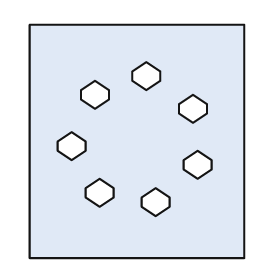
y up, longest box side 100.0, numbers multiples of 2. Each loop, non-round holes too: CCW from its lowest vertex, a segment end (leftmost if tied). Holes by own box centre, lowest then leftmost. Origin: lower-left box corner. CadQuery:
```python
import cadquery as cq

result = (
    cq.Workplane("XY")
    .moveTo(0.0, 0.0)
    .lineTo(92.0, 0.0)
    .lineTo(92.0, 100.0)
    .lineTo(0.0, 100.0)
    .close()
    .moveTo(54.0, 18.0)
    .lineTo(60.0, 22.0)
    .lineTo(60.0, 26.0)
    .lineTo(54.0, 30.0)
    .lineTo(48.0, 26.0)
    .lineTo(48.0, 22.0)
    .close()
    .moveTo(30.0, 22.0)
    .lineTo(36.0, 26.0)
    .lineTo(36.0, 30.0)
    .lineTo(30.0, 34.0)
    .lineTo(24.0, 30.0)
    .lineTo(24.0, 26.0)
    .close()
    .moveTo(72.0, 34.0)
    .lineTo(78.0, 38.0)
    .lineTo(78.0, 42.0)
    .lineTo(72.0, 46.0)
    .lineTo(66.0, 42.0)
    .lineTo(66.0, 38.0)
    .close()
    .moveTo(18.0, 42.0)
    .lineTo(24.0, 46.0)
    .lineTo(24.0, 50.0)
    .lineTo(18.0, 54.0)
    .lineTo(12.0, 50.0)
    .lineTo(12.0, 46.0)
    .close()
    .moveTo(70.0, 58.0)
    .lineTo(76.0, 62.0)
    .lineTo(76.0, 66.0)
    .lineTo(70.0, 70.0)
    .lineTo(64.0, 66.0)
    .lineTo(64.0, 62.0)
    .close()
    .moveTo(28.0, 64.0)
    .lineTo(34.0, 68.0)
    .lineTo(34.0, 72.0)
    .lineTo(28.0, 76.0)
    .lineTo(22.0, 72.0)
    .lineTo(22.0, 68.0)
    .close()
    .moveTo(50.0, 72.0)
    .lineTo(56.0, 76.0)
    .lineTo(56.0, 80.0)
    .lineTo(50.0, 84.0)
    .lineTo(44.0, 80.0)
    .lineTo(44.0, 76.0)
    .close()
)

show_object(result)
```